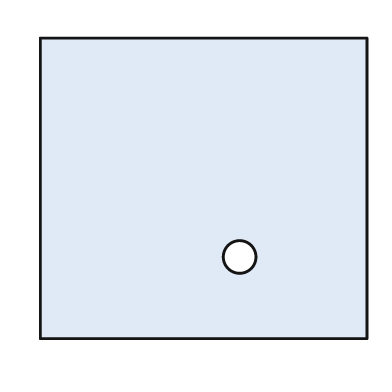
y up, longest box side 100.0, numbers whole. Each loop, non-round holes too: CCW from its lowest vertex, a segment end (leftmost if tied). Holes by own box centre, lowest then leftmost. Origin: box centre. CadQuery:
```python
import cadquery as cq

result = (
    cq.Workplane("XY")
    .moveTo(-50.0, -46.0)
    .lineTo(50.0, -46.0)
    .lineTo(50.0, 46.0)
    .lineTo(-50.0, 46.0)
    .close()
    .moveTo(11.0, -21.0)
    .circle(5.0)
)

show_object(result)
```